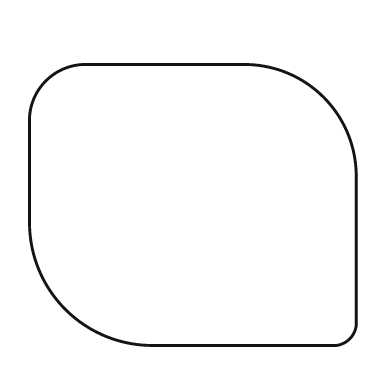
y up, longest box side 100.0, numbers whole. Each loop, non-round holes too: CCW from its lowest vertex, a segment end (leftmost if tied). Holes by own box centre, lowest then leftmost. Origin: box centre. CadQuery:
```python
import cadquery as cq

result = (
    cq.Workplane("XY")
    .moveTo(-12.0, -43.0)
    .lineTo(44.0, -43.0)
    .threePointArc((48.0, -41.0), (50.0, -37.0))
    .lineTo(50.0, 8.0)
    .threePointArc((40.0, 33.0), (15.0, 43.0))
    .lineTo(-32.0, 43.0)
    .threePointArc((-45.0, 38.0), (-50.0, 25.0))
    .lineTo(-50.0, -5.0)
    .threePointArc((-39.0, -32.0), (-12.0, -43.0))
    .close()
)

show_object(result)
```